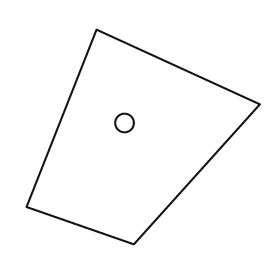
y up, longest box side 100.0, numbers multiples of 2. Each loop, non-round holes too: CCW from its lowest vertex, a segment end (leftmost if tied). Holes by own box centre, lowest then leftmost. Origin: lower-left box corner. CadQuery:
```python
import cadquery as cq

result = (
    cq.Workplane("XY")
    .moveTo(46.0, 0.0)
    .lineTo(100.0, 60.0)
    .lineTo(30.0, 92.0)
    .lineTo(0.0, 16.0)
    .close()
    .moveTo(42.0, 52.0)
    .circle(4.0)
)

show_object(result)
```